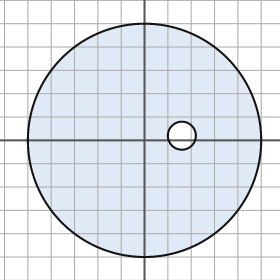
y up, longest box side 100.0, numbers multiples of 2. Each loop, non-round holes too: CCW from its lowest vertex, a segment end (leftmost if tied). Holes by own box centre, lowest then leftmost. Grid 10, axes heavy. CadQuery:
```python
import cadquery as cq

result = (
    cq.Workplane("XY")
    .moveTo(0.0, 0.0)
    .circle(50.0)
    .moveTo(16.0, 2.0)
    .circle(6.0)
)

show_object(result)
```